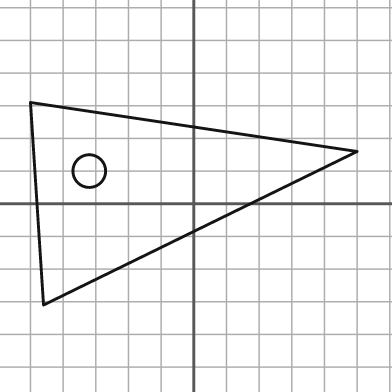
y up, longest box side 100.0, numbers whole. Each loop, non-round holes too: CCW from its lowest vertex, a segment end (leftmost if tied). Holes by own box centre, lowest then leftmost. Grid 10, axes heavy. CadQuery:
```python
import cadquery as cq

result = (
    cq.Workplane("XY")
    .moveTo(-46.0, -31.0)
    .lineTo(50.0, 16.0)
    .lineTo(-50.0, 31.0)
    .close()
    .moveTo(-32.0, 10.0)
    .circle(5.0)
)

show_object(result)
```